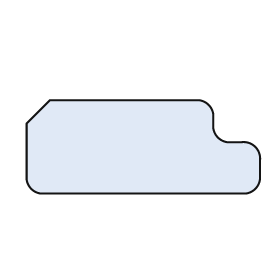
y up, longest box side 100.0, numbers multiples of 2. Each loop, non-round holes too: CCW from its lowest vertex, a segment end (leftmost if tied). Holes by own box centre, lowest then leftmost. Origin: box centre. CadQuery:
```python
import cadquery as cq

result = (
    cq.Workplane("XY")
    .moveTo(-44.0, -20.0)
    .lineTo(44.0, -20.0)
    .threePointArc((48.0, -18.0), (50.0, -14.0))
    .lineTo(50.0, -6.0)
    .threePointArc((48.0, 0.0), (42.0, 2.0))
    .lineTo(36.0, 2.0)
    .threePointArc((32.0, 4.0), (30.0, 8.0))
    .lineTo(30.0, 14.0)
    .threePointArc((28.0, 18.0), (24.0, 20.0))
    .lineTo(-40.0, 20.0)
    .lineTo(-50.0, 10.0)
    .lineTo(-50.0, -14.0)
    .threePointArc((-48.0, -18.0), (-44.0, -20.0))
    .close()
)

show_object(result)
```